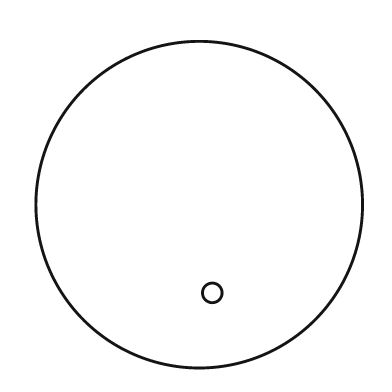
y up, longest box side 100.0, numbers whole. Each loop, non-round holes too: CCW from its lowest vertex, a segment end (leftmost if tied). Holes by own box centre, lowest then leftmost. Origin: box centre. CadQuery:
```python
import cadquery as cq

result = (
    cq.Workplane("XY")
    .moveTo(0.0, 0.0)
    .circle(50.0)
    .moveTo(4.0, -27.0)
    .circle(3.0)
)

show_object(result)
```